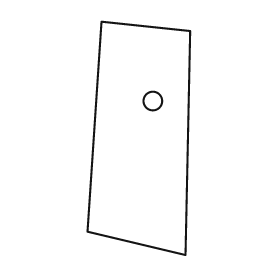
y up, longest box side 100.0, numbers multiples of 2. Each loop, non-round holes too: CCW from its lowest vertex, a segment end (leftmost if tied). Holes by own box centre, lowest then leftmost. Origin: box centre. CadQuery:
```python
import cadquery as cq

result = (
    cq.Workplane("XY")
    .moveTo(20.0, -50.0)
    .lineTo(22.0, 46.0)
    .lineTo(-16.0, 50.0)
    .lineTo(-22.0, -40.0)
    .close()
    .moveTo(6.0, 16.0)
    .circle(4.0)
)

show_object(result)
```